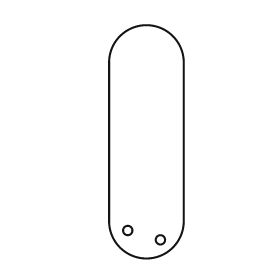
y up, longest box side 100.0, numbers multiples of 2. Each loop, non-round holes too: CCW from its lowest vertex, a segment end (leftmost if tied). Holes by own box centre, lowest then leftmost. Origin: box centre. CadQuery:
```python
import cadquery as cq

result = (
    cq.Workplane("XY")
    .moveTo(-16.0, -34.0)
    .threePointArc((0.0, -50.0), (16.0, -34.0))
    .lineTo(16.0, 34.0)
    .threePointArc((0.0, 50.0), (-16.0, 34.0))
    .close()
    .moveTo(6.0, -42.0)
    .circle(2.0)
    .moveTo(-8.0, -38.0)
    .circle(2.0)
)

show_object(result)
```